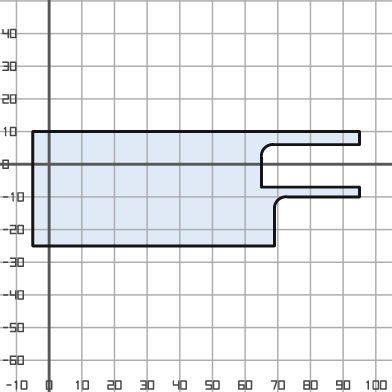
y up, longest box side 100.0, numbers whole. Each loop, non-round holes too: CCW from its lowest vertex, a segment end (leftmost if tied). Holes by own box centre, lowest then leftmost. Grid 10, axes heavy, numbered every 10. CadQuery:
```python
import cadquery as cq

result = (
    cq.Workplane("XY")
    .moveTo(-5.0, -25.0)
    .lineTo(69.0, -25.0)
    .lineTo(69.0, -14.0)
    .threePointArc((70.0, -11.0), (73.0, -10.0))
    .lineTo(95.0, -10.0)
    .lineTo(95.0, -7.0)
    .lineTo(65.0, -7.0)
    .lineTo(65.0, 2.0)
    .threePointArc((66.0, 5.0), (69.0, 6.0))
    .lineTo(95.0, 6.0)
    .lineTo(95.0, 10.0)
    .lineTo(-5.0, 10.0)
    .close()
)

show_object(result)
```